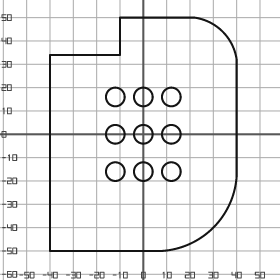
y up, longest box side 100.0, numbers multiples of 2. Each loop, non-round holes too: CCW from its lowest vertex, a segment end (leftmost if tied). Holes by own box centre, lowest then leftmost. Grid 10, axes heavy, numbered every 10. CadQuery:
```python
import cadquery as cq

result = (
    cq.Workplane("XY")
    .moveTo(-40.0, -50.0)
    .lineTo(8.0, -50.0)
    .threePointArc((30.0, -40.0), (40.0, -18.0))
    .lineTo(40.0, 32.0)
    .threePointArc((34.0, 44.0), (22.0, 50.0))
    .lineTo(-10.0, 50.0)
    .lineTo(-10.0, 34.0)
    .lineTo(-40.0, 34.0)
    .close()
    .moveTo(-12.0, -16.0)
    .circle(4.0)
    .moveTo(0.0, -16.0)
    .circle(4.0)
    .moveTo(12.0, -16.0)
    .circle(4.0)
    .moveTo(-12.0, 0.0)
    .circle(4.0)
    .moveTo(0.0, 0.0)
    .circle(4.0)
    .moveTo(12.0, 0.0)
    .circle(4.0)
    .moveTo(-12.0, 16.0)
    .circle(4.0)
    .moveTo(0.0, 16.0)
    .circle(4.0)
    .moveTo(12.0, 16.0)
    .circle(4.0)
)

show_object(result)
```